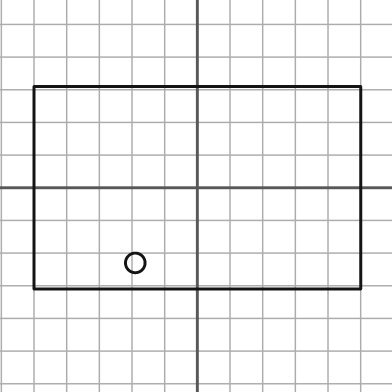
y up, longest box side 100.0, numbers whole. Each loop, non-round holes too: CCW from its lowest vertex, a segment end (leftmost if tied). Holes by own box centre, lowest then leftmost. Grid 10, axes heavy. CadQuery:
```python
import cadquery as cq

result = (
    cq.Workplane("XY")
    .moveTo(-50.0, -31.0)
    .lineTo(50.0, -31.0)
    .lineTo(50.0, 31.0)
    .lineTo(-50.0, 31.0)
    .close()
    .moveTo(-19.0, -23.0)
    .circle(3.0)
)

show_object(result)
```